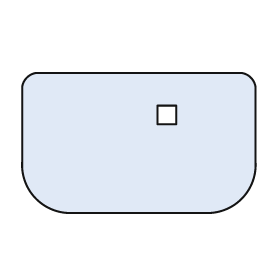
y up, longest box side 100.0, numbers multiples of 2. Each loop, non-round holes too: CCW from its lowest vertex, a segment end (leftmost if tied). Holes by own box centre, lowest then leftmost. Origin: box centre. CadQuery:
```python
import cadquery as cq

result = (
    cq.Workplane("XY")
    .moveTo(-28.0, -30.0)
    .lineTo(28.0, -30.0)
    .threePointArc((44.0, -24.0), (50.0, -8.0))
    .lineTo(50.0, 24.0)
    .threePointArc((48.0, 28.0), (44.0, 30.0))
    .lineTo(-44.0, 30.0)
    .threePointArc((-48.0, 28.0), (-50.0, 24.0))
    .lineTo(-50.0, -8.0)
    .threePointArc((-44.0, -24.0), (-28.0, -30.0))
    .close()
    .moveTo(8.0, 8.0)
    .lineTo(16.0, 8.0)
    .lineTo(16.0, 16.0)
    .lineTo(8.0, 16.0)
    .close()
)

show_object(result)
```